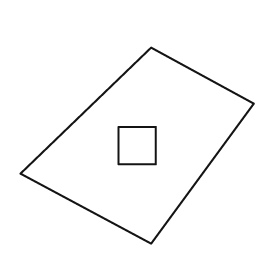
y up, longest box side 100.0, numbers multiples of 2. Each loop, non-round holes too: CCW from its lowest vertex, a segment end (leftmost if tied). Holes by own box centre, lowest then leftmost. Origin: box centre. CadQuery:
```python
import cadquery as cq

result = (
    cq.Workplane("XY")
    .moveTo(6.0, -42.0)
    .lineTo(50.0, 18.0)
    .lineTo(6.0, 42.0)
    .lineTo(-50.0, -12.0)
    .close()
    .moveTo(-8.0, -8.0)
    .lineTo(8.0, -8.0)
    .lineTo(8.0, 8.0)
    .lineTo(-8.0, 8.0)
    .close()
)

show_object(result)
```